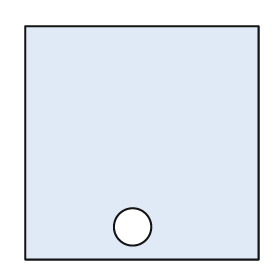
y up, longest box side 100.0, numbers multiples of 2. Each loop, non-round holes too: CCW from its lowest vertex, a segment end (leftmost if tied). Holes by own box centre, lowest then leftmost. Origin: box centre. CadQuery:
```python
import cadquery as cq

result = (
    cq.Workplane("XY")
    .moveTo(-50.0, -50.0)
    .lineTo(50.0, -50.0)
    .lineTo(50.0, 50.0)
    .lineTo(-50.0, 50.0)
    .close()
    .moveTo(-4.0, -36.0)
    .circle(8.0)
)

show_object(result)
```